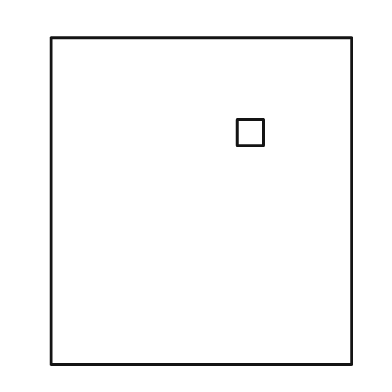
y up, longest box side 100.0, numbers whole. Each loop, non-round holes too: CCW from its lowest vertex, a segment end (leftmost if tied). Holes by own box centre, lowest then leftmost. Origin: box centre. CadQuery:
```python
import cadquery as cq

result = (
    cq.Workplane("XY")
    .moveTo(-46.0, -50.0)
    .lineTo(46.0, -50.0)
    .lineTo(46.0, 50.0)
    .lineTo(-46.0, 50.0)
    .close()
    .moveTo(11.0, 17.0)
    .lineTo(19.0, 17.0)
    .lineTo(19.0, 25.0)
    .lineTo(11.0, 25.0)
    .close()
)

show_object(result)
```